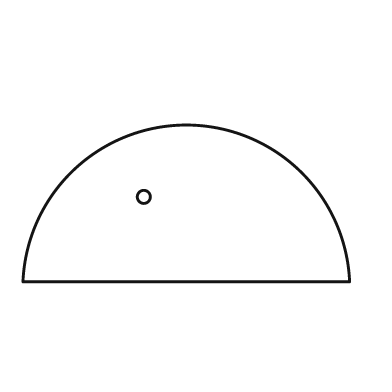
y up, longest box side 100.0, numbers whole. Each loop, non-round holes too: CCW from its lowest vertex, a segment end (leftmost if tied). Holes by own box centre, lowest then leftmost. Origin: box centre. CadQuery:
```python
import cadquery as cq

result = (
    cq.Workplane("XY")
    .moveTo(-50.0, -24.0)
    .lineTo(50.0, -24.0)
    .threePointArc((0.0, 24.0), (-50.0, -24.0))
    .close()
    .moveTo(-13.0, 2.0)
    .circle(2.0)
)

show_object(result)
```